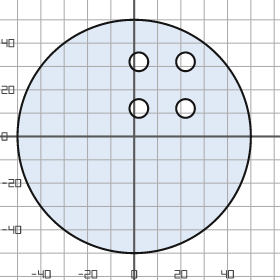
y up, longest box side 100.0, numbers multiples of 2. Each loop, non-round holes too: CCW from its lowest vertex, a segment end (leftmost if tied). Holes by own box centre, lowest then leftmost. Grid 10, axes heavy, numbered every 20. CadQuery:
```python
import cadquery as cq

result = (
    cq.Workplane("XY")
    .moveTo(0.0, 0.0)
    .circle(50.0)
    .moveTo(2.0, 12.0)
    .circle(4.0)
    .moveTo(22.0, 12.0)
    .circle(4.0)
    .moveTo(2.0, 32.0)
    .circle(4.0)
    .moveTo(22.0, 32.0)
    .circle(4.0)
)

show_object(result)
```